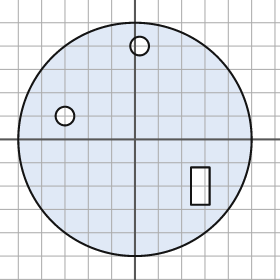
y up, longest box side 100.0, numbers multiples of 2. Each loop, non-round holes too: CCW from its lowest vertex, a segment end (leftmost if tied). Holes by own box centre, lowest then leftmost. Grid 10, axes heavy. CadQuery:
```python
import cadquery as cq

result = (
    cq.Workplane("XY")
    .moveTo(0.0, 0.0)
    .circle(50.0)
    .moveTo(24.0, -28.0)
    .lineTo(32.0, -28.0)
    .lineTo(32.0, -12.0)
    .lineTo(24.0, -12.0)
    .close()
    .moveTo(-30.0, 10.0)
    .circle(4.0)
    .moveTo(2.0, 40.0)
    .circle(4.0)
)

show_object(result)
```